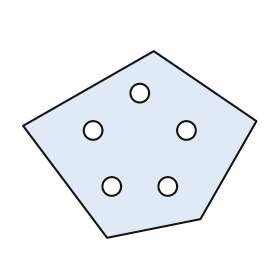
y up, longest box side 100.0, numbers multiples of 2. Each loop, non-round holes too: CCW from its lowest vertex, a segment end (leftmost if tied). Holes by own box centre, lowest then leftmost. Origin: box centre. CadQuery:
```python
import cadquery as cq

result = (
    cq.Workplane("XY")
    .moveTo(-14.0, -40.0)
    .lineTo(26.0, -32.0)
    .lineTo(50.0, 10.0)
    .lineTo(6.0, 40.0)
    .lineTo(-50.0, 8.0)
    .close()
    .moveTo(-12.0, -18.0)
    .circle(4.0)
    .moveTo(12.0, -18.0)
    .circle(4.0)
    .moveTo(-20.0, 6.0)
    .circle(4.0)
    .moveTo(20.0, 6.0)
    .circle(4.0)
    .moveTo(0.0, 22.0)
    .circle(4.0)
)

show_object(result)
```